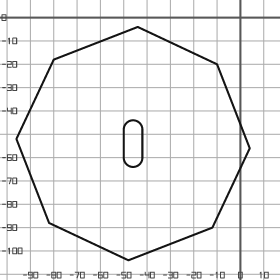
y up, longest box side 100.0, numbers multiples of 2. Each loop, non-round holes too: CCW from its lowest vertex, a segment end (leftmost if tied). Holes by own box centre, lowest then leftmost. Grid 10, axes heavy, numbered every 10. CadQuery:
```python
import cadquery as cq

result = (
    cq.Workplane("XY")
    .moveTo(-48.0, -104.0)
    .lineTo(-12.0, -90.0)
    .lineTo(4.0, -56.0)
    .lineTo(-10.0, -20.0)
    .lineTo(-44.0, -4.0)
    .lineTo(-80.0, -18.0)
    .lineTo(-96.0, -52.0)
    .lineTo(-82.0, -88.0)
    .close()
    .moveTo(-50.0, -60.0)
    .threePointArc((-46.0, -64.0), (-42.0, -60.0))
    .lineTo(-42.0, -48.0)
    .threePointArc((-46.0, -44.0), (-50.0, -48.0))
    .close()
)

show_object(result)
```